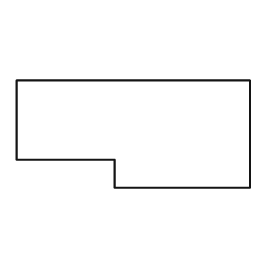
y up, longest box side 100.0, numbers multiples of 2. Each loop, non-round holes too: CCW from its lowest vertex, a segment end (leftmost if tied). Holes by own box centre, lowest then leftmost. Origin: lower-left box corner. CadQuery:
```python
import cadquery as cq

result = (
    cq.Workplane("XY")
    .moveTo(42.0, 0.0)
    .lineTo(100.0, 0.0)
    .lineTo(100.0, 46.0)
    .lineTo(0.0, 46.0)
    .lineTo(0.0, 12.0)
    .lineTo(42.0, 12.0)
    .close()
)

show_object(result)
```